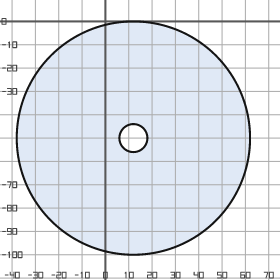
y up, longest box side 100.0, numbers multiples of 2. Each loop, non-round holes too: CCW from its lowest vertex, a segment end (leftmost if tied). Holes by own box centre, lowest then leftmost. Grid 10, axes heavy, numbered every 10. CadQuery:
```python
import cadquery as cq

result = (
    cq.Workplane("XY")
    .moveTo(12.0, -50.0)
    .circle(50.0)
    .moveTo(12.0, -50.0)
    .circle(6.0)
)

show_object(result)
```